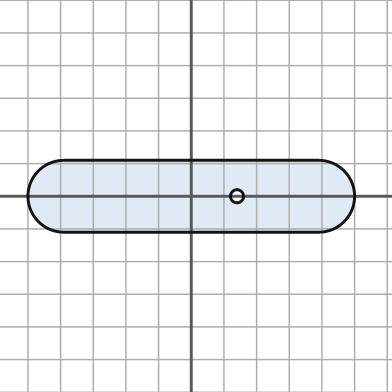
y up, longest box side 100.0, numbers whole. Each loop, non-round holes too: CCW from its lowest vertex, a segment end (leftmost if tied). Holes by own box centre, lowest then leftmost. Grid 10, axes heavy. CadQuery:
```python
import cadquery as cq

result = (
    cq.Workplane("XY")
    .moveTo(-39.0, -11.0)
    .lineTo(39.0, -11.0)
    .threePointArc((50.0, 0.0), (39.0, 11.0))
    .lineTo(-39.0, 11.0)
    .threePointArc((-50.0, 0.0), (-39.0, -11.0))
    .close()
    .moveTo(14.0, 0.0)
    .circle(2.0)
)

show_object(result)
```